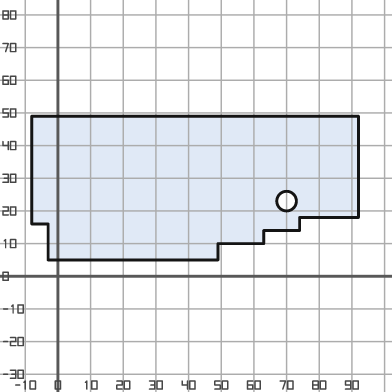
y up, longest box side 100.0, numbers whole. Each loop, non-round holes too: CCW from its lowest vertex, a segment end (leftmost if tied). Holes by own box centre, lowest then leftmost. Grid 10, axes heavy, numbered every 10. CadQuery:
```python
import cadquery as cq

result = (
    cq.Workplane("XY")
    .moveTo(-3.0, 5.0)
    .lineTo(49.0, 5.0)
    .lineTo(49.0, 10.0)
    .lineTo(63.0, 10.0)
    .lineTo(63.0, 14.0)
    .lineTo(74.0, 14.0)
    .lineTo(74.0, 18.0)
    .lineTo(92.0, 18.0)
    .lineTo(92.0, 49.0)
    .lineTo(-8.0, 49.0)
    .lineTo(-8.0, 16.0)
    .lineTo(-3.0, 16.0)
    .close()
    .moveTo(70.0, 23.0)
    .circle(3.0)
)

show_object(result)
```